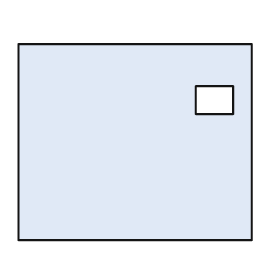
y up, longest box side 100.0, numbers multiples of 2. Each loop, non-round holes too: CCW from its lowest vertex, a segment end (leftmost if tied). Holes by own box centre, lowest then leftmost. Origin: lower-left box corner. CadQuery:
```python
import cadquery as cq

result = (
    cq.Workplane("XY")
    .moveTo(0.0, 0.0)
    .lineTo(100.0, 0.0)
    .lineTo(100.0, 84.0)
    .lineTo(0.0, 84.0)
    .close()
    .moveTo(76.0, 54.0)
    .lineTo(92.0, 54.0)
    .lineTo(92.0, 66.0)
    .lineTo(76.0, 66.0)
    .close()
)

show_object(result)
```